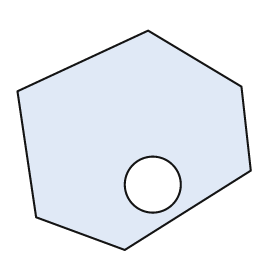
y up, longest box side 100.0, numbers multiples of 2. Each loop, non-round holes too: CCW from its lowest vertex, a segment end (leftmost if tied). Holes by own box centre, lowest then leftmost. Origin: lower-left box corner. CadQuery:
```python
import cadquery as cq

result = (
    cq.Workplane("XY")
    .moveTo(46.0, 0.0)
    .lineTo(100.0, 34.0)
    .lineTo(96.0, 70.0)
    .lineTo(56.0, 94.0)
    .lineTo(0.0, 68.0)
    .lineTo(8.0, 14.0)
    .close()
    .moveTo(58.0, 28.0)
    .circle(12.0)
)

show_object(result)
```